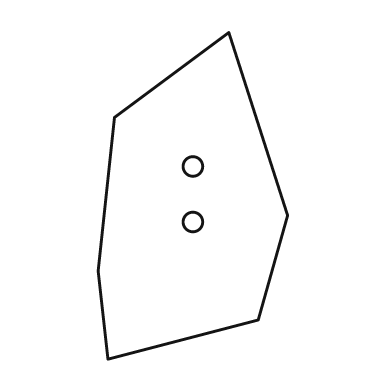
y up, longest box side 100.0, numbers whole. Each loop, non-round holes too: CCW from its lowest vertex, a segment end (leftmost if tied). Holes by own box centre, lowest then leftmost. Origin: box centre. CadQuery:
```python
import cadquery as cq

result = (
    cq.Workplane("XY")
    .moveTo(-26.0, -50.0)
    .lineTo(20.0, -38.0)
    .lineTo(29.0, -6.0)
    .lineTo(11.0, 50.0)
    .lineTo(-24.0, 24.0)
    .lineTo(-29.0, -23.0)
    .close()
    .moveTo(0.0, -8.0)
    .circle(3.0)
    .moveTo(0.0, 9.0)
    .circle(3.0)
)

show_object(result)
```